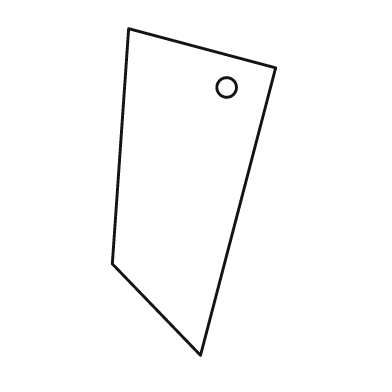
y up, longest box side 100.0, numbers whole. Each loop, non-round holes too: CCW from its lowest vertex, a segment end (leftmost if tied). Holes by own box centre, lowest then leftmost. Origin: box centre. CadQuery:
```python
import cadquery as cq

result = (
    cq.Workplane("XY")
    .moveTo(2.0, -50.0)
    .lineTo(25.0, 38.0)
    .lineTo(-20.0, 50.0)
    .lineTo(-25.0, -22.0)
    .close()
    .moveTo(10.0, 32.0)
    .circle(3.0)
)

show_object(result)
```